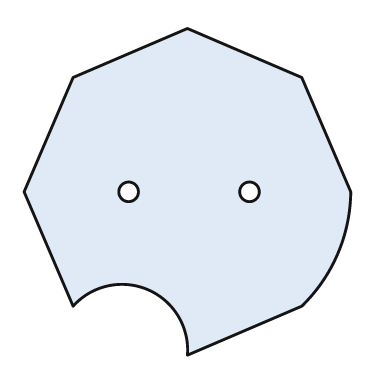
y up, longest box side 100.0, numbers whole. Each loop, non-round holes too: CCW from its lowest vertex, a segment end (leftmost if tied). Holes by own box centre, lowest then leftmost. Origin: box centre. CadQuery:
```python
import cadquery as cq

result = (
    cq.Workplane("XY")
    .moveTo(0.0, -50.0)
    .lineTo(35.0, -35.0)
    .threePointArc((46.0, -19.0), (50.0, 0.0))
    .lineTo(35.0, 35.0)
    .lineTo(0.0, 50.0)
    .lineTo(-35.0, 35.0)
    .lineTo(-50.0, 0.0)
    .lineTo(-35.0, -35.0)
    .threePointArc((-12.0, -30.0), (0.0, -50.0))
    .close()
    .moveTo(-18.0, 0.0)
    .circle(3.0)
    .moveTo(19.0, 0.0)
    .circle(3.0)
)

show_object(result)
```